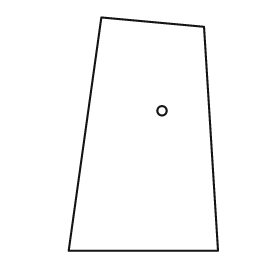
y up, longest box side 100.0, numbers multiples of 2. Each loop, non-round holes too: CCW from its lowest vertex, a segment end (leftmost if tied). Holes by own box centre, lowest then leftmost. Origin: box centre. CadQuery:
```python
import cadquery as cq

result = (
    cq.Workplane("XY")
    .moveTo(-32.0, -50.0)
    .lineTo(32.0, -50.0)
    .lineTo(26.0, 46.0)
    .lineTo(-18.0, 50.0)
    .close()
    .moveTo(8.0, 10.0)
    .circle(2.0)
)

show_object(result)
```